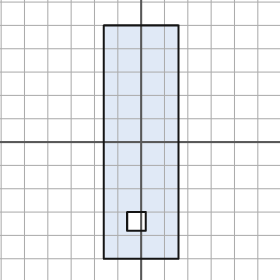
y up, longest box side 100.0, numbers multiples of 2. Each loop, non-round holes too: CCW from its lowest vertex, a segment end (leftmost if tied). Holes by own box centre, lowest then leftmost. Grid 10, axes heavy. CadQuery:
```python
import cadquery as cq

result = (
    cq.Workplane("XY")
    .moveTo(-16.0, -50.0)
    .lineTo(16.0, -50.0)
    .lineTo(16.0, 50.0)
    .lineTo(-16.0, 50.0)
    .close()
    .moveTo(-6.0, -38.0)
    .lineTo(2.0, -38.0)
    .lineTo(2.0, -30.0)
    .lineTo(-6.0, -30.0)
    .close()
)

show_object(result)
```